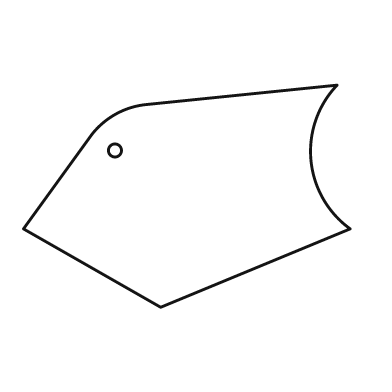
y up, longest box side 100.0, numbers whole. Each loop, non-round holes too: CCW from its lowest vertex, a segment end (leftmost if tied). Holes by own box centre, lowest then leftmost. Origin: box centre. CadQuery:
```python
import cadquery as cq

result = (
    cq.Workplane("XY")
    .moveTo(-8.0, -34.0)
    .lineTo(50.0, -10.0)
    .threePointArc((38.0, 11.0), (46.0, 34.0))
    .lineTo(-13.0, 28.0)
    .threePointArc((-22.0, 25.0), (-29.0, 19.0))
    .lineTo(-50.0, -10.0)
    .close()
    .moveTo(-22.0, 14.0)
    .circle(2.0)
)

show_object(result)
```